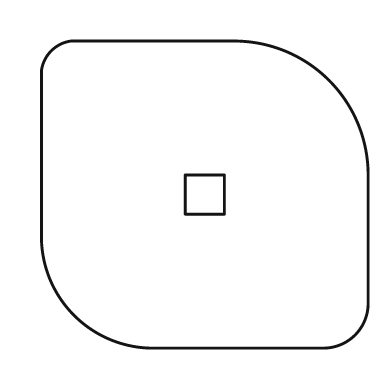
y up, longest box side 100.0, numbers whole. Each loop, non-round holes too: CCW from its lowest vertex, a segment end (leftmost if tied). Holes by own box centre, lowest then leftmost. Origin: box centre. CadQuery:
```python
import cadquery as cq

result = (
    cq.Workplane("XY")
    .moveTo(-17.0, -47.0)
    .lineTo(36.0, -47.0)
    .threePointArc((46.0, -43.0), (50.0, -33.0))
    .lineTo(50.0, 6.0)
    .threePointArc((38.0, 35.0), (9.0, 47.0))
    .lineTo(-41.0, 47.0)
    .threePointArc((-47.0, 44.0), (-50.0, 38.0))
    .lineTo(-50.0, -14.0)
    .threePointArc((-40.0, -37.0), (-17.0, -47.0))
    .close()
    .moveTo(-6.0, -6.0)
    .lineTo(6.0, -6.0)
    .lineTo(6.0, 6.0)
    .lineTo(-6.0, 6.0)
    .close()
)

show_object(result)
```